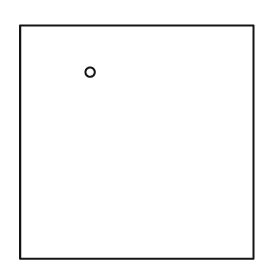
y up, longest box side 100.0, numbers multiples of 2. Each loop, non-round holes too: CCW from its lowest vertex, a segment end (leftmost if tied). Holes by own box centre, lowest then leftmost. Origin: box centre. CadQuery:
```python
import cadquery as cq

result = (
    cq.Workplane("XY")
    .moveTo(-50.0, -50.0)
    .lineTo(50.0, -50.0)
    .lineTo(50.0, 50.0)
    .lineTo(-50.0, 50.0)
    .close()
    .moveTo(-20.0, 30.0)
    .circle(2.0)
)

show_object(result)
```